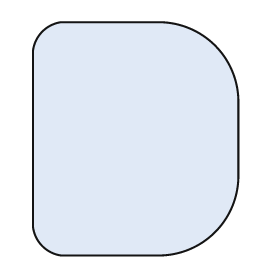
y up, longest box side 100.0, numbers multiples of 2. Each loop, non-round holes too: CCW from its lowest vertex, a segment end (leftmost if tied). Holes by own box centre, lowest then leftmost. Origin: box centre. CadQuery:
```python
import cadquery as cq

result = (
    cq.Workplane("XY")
    .moveTo(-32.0, -50.0)
    .lineTo(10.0, -50.0)
    .threePointArc((34.0, -40.0), (44.0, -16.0))
    .lineTo(44.0, 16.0)
    .threePointArc((34.0, 40.0), (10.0, 50.0))
    .lineTo(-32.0, 50.0)
    .threePointArc((-40.0, 46.0), (-44.0, 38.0))
    .lineTo(-44.0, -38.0)
    .threePointArc((-40.0, -46.0), (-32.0, -50.0))
    .close()
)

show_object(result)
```